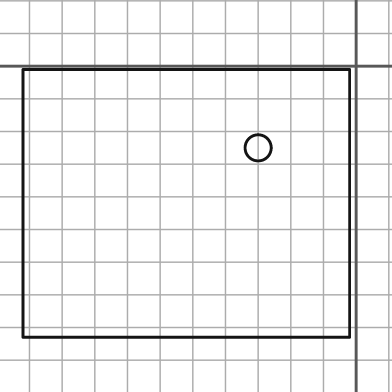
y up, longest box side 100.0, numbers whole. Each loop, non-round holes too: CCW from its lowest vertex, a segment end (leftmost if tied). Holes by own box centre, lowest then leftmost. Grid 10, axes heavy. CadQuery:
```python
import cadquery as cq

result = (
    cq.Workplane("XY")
    .moveTo(-102.0, -83.0)
    .lineTo(-2.0, -83.0)
    .lineTo(-2.0, -1.0)
    .lineTo(-102.0, -1.0)
    .close()
    .moveTo(-30.0, -25.0)
    .circle(4.0)
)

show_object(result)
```